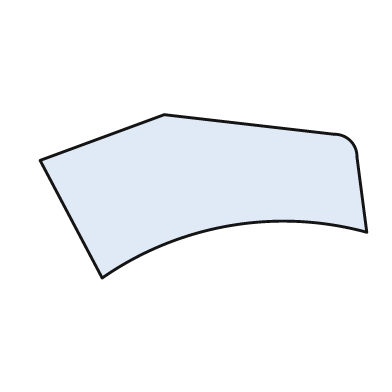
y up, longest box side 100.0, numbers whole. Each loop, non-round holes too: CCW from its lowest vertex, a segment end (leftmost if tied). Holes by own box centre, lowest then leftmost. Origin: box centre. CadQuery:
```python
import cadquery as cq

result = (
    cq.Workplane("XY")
    .moveTo(-31.0, -25.0)
    .threePointArc((8.0, -9.0), (50.0, -11.0))
    .lineTo(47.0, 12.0)
    .threePointArc((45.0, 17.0), (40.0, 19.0))
    .lineTo(-12.0, 25.0)
    .lineTo(-50.0, 11.0)
    .close()
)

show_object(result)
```